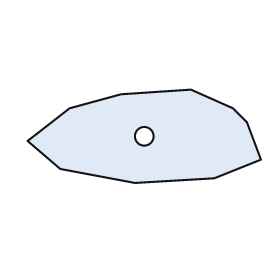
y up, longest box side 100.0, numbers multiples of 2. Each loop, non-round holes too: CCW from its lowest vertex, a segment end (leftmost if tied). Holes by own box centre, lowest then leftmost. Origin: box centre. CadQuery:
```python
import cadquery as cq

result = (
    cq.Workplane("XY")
    .moveTo(-4.0, -20.0)
    .lineTo(30.0, -18.0)
    .lineTo(50.0, -10.0)
    .lineTo(44.0, 6.0)
    .lineTo(38.0, 12.0)
    .lineTo(20.0, 20.0)
    .lineTo(-10.0, 18.0)
    .lineTo(-32.0, 12.0)
    .lineTo(-50.0, -2.0)
    .lineTo(-36.0, -14.0)
    .close()
    .moveTo(0.0, 0.0)
    .circle(4.0)
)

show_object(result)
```